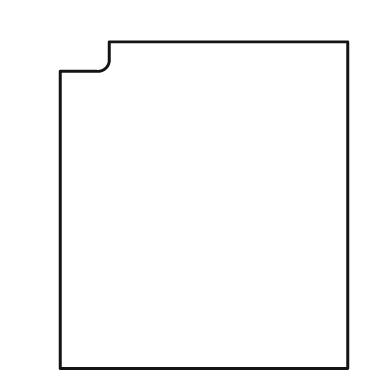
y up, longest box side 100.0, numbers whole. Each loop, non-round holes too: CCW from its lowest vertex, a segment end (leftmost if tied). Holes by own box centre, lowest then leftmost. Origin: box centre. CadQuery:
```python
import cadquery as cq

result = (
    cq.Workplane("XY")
    .moveTo(-44.0, -50.0)
    .lineTo(44.0, -50.0)
    .lineTo(44.0, 50.0)
    .lineTo(-29.0, 50.0)
    .lineTo(-29.0, 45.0)
    .threePointArc((-30.0, 42.0), (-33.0, 41.0))
    .lineTo(-44.0, 41.0)
    .close()
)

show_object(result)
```